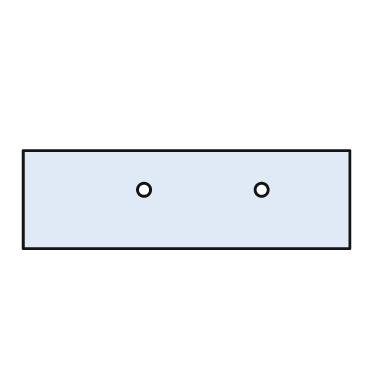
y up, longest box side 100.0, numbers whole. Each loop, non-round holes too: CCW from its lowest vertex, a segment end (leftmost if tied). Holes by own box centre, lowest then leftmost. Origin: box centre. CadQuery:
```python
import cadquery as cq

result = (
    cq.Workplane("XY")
    .moveTo(-50.0, -15.0)
    .lineTo(50.0, -15.0)
    .lineTo(50.0, 15.0)
    .lineTo(-50.0, 15.0)
    .close()
    .moveTo(-13.0, 3.0)
    .circle(2.0)
    .moveTo(23.0, 3.0)
    .circle(2.0)
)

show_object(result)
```